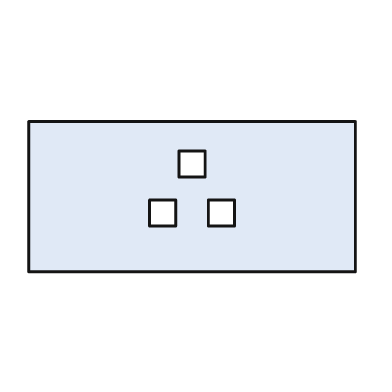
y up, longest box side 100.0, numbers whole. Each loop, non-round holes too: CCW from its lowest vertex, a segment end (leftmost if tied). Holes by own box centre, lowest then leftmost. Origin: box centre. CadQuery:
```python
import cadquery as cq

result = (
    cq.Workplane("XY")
    .moveTo(-50.0, -23.0)
    .lineTo(50.0, -23.0)
    .lineTo(50.0, 23.0)
    .lineTo(-50.0, 23.0)
    .close()
    .moveTo(-13.0, -9.0)
    .lineTo(-5.0, -9.0)
    .lineTo(-5.0, -1.0)
    .lineTo(-13.0, -1.0)
    .close()
    .moveTo(5.0, -9.0)
    .lineTo(13.0, -9.0)
    .lineTo(13.0, -1.0)
    .lineTo(5.0, -1.0)
    .close()
    .moveTo(-4.0, 6.0)
    .lineTo(4.0, 6.0)
    .lineTo(4.0, 14.0)
    .lineTo(-4.0, 14.0)
    .close()
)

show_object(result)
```